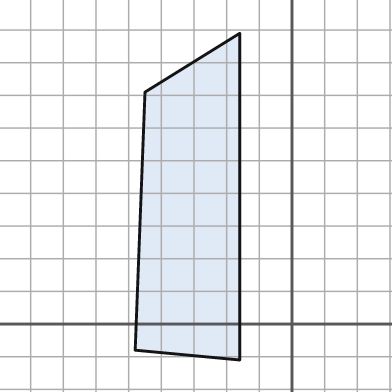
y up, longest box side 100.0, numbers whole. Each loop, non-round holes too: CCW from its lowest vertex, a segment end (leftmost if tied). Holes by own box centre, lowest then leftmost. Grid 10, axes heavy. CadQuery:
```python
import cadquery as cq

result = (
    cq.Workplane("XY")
    .moveTo(-16.0, -11.0)
    .lineTo(-16.0, 89.0)
    .lineTo(-45.0, 71.0)
    .lineTo(-48.0, -8.0)
    .close()
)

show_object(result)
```